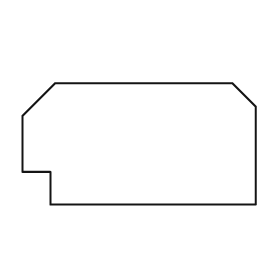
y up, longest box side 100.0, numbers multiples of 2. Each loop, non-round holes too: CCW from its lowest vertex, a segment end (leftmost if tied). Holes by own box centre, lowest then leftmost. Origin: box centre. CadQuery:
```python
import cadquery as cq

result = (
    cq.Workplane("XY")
    .moveTo(-38.0, -26.0)
    .lineTo(50.0, -26.0)
    .lineTo(50.0, 16.0)
    .lineTo(40.0, 26.0)
    .lineTo(-36.0, 26.0)
    .lineTo(-50.0, 12.0)
    .lineTo(-50.0, -12.0)
    .lineTo(-38.0, -12.0)
    .close()
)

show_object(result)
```